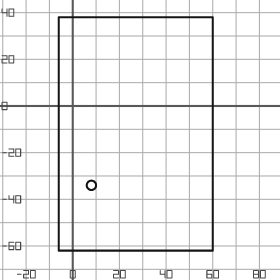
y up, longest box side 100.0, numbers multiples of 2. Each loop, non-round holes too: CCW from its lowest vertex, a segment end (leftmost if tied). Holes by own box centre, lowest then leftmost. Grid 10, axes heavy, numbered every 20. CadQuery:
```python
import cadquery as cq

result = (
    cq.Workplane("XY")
    .moveTo(-6.0, -62.0)
    .lineTo(60.0, -62.0)
    .lineTo(60.0, 38.0)
    .lineTo(-6.0, 38.0)
    .close()
    .moveTo(8.0, -34.0)
    .circle(2.0)
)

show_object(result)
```